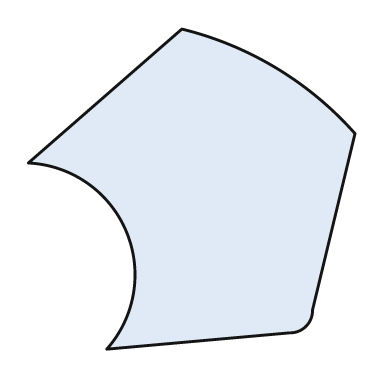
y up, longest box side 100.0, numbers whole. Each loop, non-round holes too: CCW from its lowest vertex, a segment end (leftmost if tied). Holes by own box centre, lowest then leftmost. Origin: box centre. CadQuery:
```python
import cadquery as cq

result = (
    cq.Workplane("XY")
    .moveTo(-26.0, -49.0)
    .lineTo(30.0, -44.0)
    .threePointArc((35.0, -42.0), (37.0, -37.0))
    .lineTo(50.0, 17.0)
    .threePointArc((26.0, 37.0), (-3.0, 49.0))
    .lineTo(-50.0, 8.0)
    .threePointArc((-20.0, -13.0), (-26.0, -49.0))
    .close()
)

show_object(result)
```